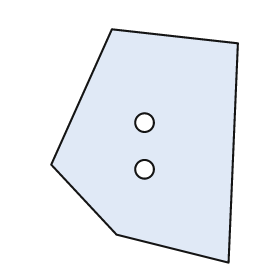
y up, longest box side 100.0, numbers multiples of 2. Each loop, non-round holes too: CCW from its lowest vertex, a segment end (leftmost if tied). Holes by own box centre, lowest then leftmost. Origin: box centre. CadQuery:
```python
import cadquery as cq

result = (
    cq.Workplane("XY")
    .moveTo(36.0, -50.0)
    .lineTo(40.0, 44.0)
    .lineTo(-14.0, 50.0)
    .lineTo(-40.0, -8.0)
    .lineTo(-12.0, -38.0)
    .close()
    .moveTo(0.0, -10.0)
    .circle(4.0)
    .moveTo(0.0, 10.0)
    .circle(4.0)
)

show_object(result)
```